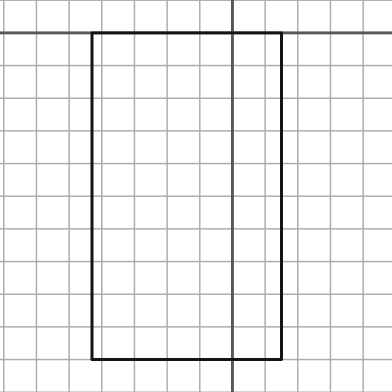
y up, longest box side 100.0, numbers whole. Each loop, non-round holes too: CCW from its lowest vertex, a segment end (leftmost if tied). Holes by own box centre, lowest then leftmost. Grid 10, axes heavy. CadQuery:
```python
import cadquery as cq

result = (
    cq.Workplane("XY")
    .moveTo(-43.0, -100.0)
    .lineTo(15.0, -100.0)
    .lineTo(15.0, 0.0)
    .lineTo(-43.0, 0.0)
    .close()
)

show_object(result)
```